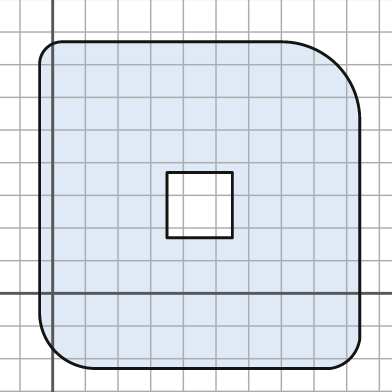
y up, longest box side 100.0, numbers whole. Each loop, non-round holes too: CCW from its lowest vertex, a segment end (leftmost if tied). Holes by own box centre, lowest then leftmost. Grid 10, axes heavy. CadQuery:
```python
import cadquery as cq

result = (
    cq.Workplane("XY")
    .moveTo(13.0, -23.0)
    .lineTo(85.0, -23.0)
    .threePointArc((91.0, -20.0), (94.0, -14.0))
    .lineTo(94.0, 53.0)
    .threePointArc((87.0, 70.0), (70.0, 77.0))
    .lineTo(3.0, 77.0)
    .threePointArc((-2.0, 75.0), (-4.0, 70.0))
    .lineTo(-4.0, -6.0)
    .threePointArc((1.0, -18.0), (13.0, -23.0))
    .close()
    .moveTo(35.0, 17.0)
    .lineTo(55.0, 17.0)
    .lineTo(55.0, 37.0)
    .lineTo(35.0, 37.0)
    .close()
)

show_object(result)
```